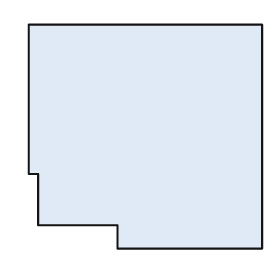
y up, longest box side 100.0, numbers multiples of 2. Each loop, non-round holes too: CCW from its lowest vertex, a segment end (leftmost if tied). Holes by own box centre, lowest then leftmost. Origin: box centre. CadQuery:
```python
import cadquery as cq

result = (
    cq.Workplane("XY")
    .moveTo(-12.0, -48.0)
    .lineTo(50.0, -48.0)
    .lineTo(50.0, 48.0)
    .lineTo(-50.0, 48.0)
    .lineTo(-50.0, -16.0)
    .lineTo(-46.0, -16.0)
    .lineTo(-46.0, -38.0)
    .lineTo(-12.0, -38.0)
    .close()
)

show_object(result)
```